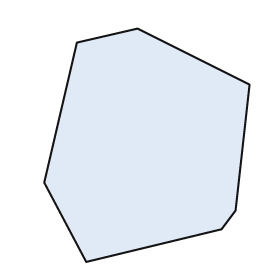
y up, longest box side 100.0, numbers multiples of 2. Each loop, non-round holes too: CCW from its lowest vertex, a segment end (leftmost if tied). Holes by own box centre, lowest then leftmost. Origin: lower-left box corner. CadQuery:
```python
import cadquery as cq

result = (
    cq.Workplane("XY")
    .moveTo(18.0, 0.0)
    .lineTo(76.0, 14.0)
    .lineTo(82.0, 22.0)
    .lineTo(88.0, 76.0)
    .lineTo(40.0, 100.0)
    .lineTo(14.0, 94.0)
    .lineTo(0.0, 34.0)
    .close()
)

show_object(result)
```